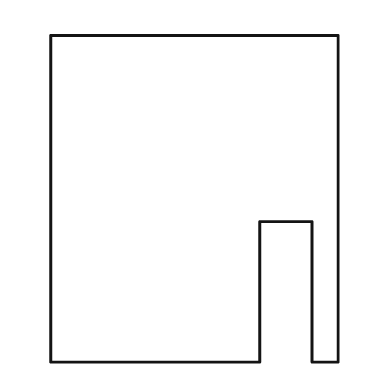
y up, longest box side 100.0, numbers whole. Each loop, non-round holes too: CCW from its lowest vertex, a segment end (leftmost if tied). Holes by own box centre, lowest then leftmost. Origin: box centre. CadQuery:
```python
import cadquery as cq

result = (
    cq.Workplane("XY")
    .moveTo(-44.0, -50.0)
    .lineTo(20.0, -50.0)
    .lineTo(20.0, -7.0)
    .lineTo(36.0, -7.0)
    .lineTo(36.0, -50.0)
    .lineTo(44.0, -50.0)
    .lineTo(44.0, 50.0)
    .lineTo(-44.0, 50.0)
    .close()
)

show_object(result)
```